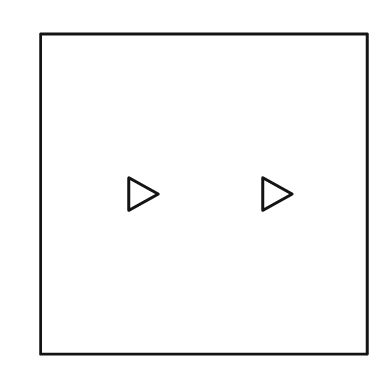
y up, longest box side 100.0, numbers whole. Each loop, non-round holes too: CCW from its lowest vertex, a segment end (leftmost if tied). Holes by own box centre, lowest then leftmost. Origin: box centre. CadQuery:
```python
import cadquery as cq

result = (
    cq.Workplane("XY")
    .moveTo(-50.0, -49.0)
    .lineTo(50.0, -49.0)
    .lineTo(50.0, 49.0)
    .lineTo(-50.0, 49.0)
    .close()
    .moveTo(-23.0, -5.0)
    .lineTo(-14.0, 0.0)
    .lineTo(-23.0, 5.0)
    .close()
    .moveTo(18.0, -5.0)
    .lineTo(27.0, 0.0)
    .lineTo(18.0, 5.0)
    .close()
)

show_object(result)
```